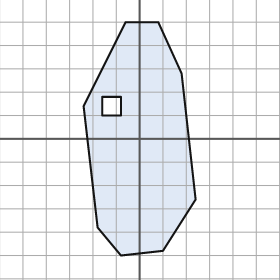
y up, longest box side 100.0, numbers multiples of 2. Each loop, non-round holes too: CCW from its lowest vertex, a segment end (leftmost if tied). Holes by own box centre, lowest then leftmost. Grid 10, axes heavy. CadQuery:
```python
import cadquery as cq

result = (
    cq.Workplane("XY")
    .moveTo(-8.0, -50.0)
    .lineTo(10.0, -48.0)
    .lineTo(24.0, -26.0)
    .lineTo(18.0, 28.0)
    .lineTo(8.0, 50.0)
    .lineTo(-6.0, 50.0)
    .lineTo(-24.0, 14.0)
    .lineTo(-18.0, -38.0)
    .close()
    .moveTo(-16.0, 10.0)
    .lineTo(-8.0, 10.0)
    .lineTo(-8.0, 18.0)
    .lineTo(-16.0, 18.0)
    .close()
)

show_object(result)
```